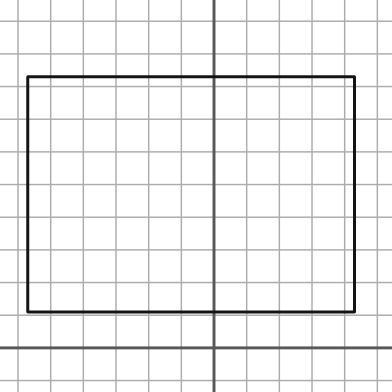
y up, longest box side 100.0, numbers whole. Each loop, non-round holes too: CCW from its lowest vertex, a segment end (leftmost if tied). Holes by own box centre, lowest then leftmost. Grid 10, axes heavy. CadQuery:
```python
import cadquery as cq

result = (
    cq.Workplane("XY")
    .moveTo(-57.0, 11.0)
    .lineTo(43.0, 11.0)
    .lineTo(43.0, 83.0)
    .lineTo(-57.0, 83.0)
    .close()
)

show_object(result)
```